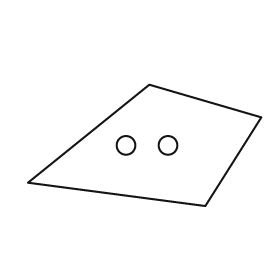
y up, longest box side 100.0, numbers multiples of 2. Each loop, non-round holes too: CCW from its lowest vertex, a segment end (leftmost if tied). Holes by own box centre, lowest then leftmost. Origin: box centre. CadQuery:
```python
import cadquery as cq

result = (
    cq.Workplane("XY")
    .moveTo(26.0, -26.0)
    .lineTo(50.0, 12.0)
    .lineTo(2.0, 26.0)
    .lineTo(-50.0, -16.0)
    .close()
    .moveTo(-8.0, 0.0)
    .circle(4.0)
    .moveTo(10.0, 0.0)
    .circle(4.0)
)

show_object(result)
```